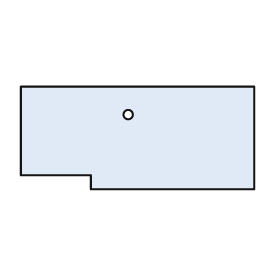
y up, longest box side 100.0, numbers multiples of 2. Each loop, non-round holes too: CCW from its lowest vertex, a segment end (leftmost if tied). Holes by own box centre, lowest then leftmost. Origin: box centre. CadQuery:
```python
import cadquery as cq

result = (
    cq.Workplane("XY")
    .moveTo(-20.0, -22.0)
    .lineTo(50.0, -22.0)
    .lineTo(50.0, 22.0)
    .lineTo(-50.0, 22.0)
    .lineTo(-50.0, -16.0)
    .lineTo(-20.0, -16.0)
    .close()
    .moveTo(-4.0, 10.0)
    .circle(2.0)
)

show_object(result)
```